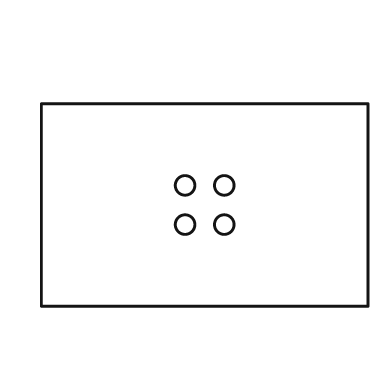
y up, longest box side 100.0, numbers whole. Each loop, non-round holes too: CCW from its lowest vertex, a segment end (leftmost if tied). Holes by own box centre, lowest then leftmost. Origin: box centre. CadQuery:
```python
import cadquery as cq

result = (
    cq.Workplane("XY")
    .moveTo(-50.0, -31.0)
    .lineTo(50.0, -31.0)
    .lineTo(50.0, 31.0)
    .lineTo(-50.0, 31.0)
    .close()
    .moveTo(-6.0, -6.0)
    .circle(3.0)
    .moveTo(6.0, -6.0)
    .circle(3.0)
    .moveTo(-6.0, 6.0)
    .circle(3.0)
    .moveTo(6.0, 6.0)
    .circle(3.0)
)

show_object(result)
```